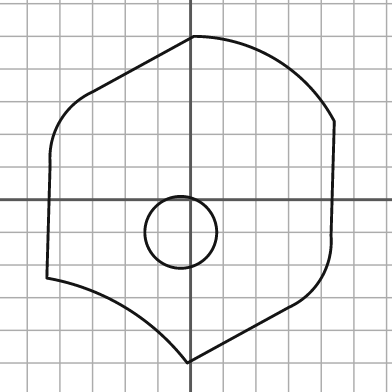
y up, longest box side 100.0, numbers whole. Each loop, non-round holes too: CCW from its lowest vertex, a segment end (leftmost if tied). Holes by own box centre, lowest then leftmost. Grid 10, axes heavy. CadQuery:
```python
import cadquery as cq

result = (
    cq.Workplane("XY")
    .moveTo(-1.0, -50.0)
    .lineTo(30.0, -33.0)
    .threePointArc((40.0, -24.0), (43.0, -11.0))
    .lineTo(44.0, 24.0)
    .threePointArc((26.0, 43.0), (1.0, 50.0))
    .lineTo(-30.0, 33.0)
    .threePointArc((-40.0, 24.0), (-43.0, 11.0))
    .lineTo(-44.0, -24.0)
    .threePointArc((-20.0, -33.0), (-1.0, -50.0))
    .close()
    .moveTo(-3.0, -10.0)
    .circle(11.0)
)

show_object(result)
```